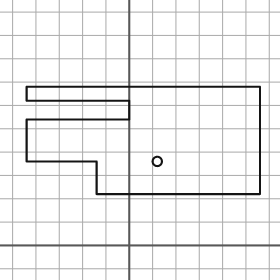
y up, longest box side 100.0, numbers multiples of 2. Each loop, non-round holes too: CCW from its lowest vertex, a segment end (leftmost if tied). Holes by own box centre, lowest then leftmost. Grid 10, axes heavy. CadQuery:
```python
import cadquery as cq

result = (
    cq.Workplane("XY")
    .moveTo(-14.0, 22.0)
    .lineTo(56.0, 22.0)
    .lineTo(56.0, 68.0)
    .lineTo(-44.0, 68.0)
    .lineTo(-44.0, 62.0)
    .lineTo(0.0, 62.0)
    .lineTo(0.0, 54.0)
    .lineTo(-44.0, 54.0)
    .lineTo(-44.0, 36.0)
    .lineTo(-14.0, 36.0)
    .close()
    .moveTo(12.0, 36.0)
    .circle(2.0)
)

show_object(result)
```